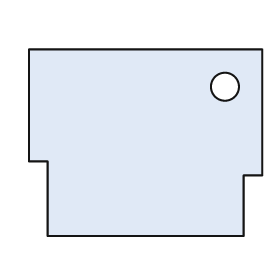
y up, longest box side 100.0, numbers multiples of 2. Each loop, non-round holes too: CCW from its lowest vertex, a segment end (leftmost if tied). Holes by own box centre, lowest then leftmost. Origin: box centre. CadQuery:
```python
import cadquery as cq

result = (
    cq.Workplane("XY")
    .moveTo(-42.0, -40.0)
    .lineTo(42.0, -40.0)
    .lineTo(42.0, -14.0)
    .lineTo(50.0, -14.0)
    .lineTo(50.0, 40.0)
    .lineTo(-50.0, 40.0)
    .lineTo(-50.0, -8.0)
    .lineTo(-42.0, -8.0)
    .close()
    .moveTo(34.0, 24.0)
    .circle(6.0)
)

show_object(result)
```